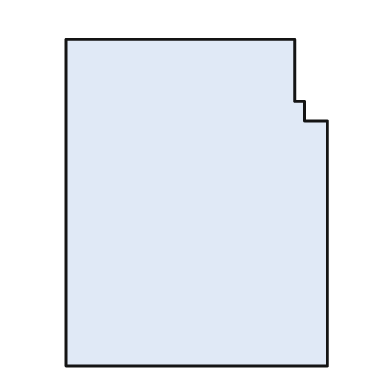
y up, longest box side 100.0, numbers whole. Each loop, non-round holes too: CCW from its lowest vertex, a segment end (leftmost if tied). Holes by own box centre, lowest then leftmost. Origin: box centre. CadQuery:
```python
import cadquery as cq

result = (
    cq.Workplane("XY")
    .moveTo(-40.0, -50.0)
    .lineTo(40.0, -50.0)
    .lineTo(40.0, 25.0)
    .lineTo(33.0, 25.0)
    .lineTo(33.0, 31.0)
    .lineTo(30.0, 31.0)
    .lineTo(30.0, 50.0)
    .lineTo(-40.0, 50.0)
    .close()
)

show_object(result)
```